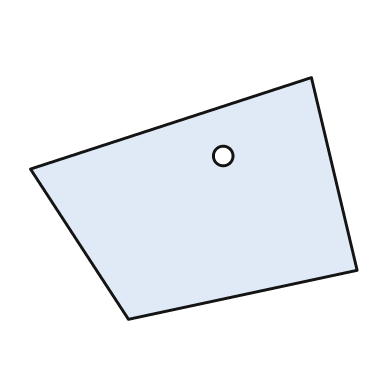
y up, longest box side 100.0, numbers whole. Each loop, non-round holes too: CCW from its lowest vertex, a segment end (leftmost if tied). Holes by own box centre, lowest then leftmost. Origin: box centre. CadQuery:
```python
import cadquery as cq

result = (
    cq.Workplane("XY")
    .moveTo(-20.0, -37.0)
    .lineTo(50.0, -22.0)
    .lineTo(36.0, 37.0)
    .lineTo(-50.0, 9.0)
    .close()
    .moveTo(9.0, 13.0)
    .circle(3.0)
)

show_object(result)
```